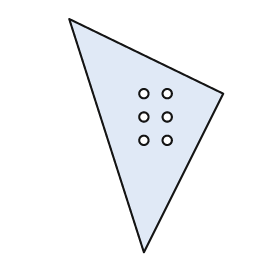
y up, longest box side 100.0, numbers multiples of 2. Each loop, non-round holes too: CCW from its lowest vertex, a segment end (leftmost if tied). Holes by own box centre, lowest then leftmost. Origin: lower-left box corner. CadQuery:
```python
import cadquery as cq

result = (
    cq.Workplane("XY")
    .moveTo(32.0, 0.0)
    .lineTo(66.0, 68.0)
    .lineTo(0.0, 100.0)
    .close()
    .moveTo(32.0, 48.0)
    .circle(2.0)
    .moveTo(42.0, 48.0)
    .circle(2.0)
    .moveTo(32.0, 58.0)
    .circle(2.0)
    .moveTo(42.0, 58.0)
    .circle(2.0)
    .moveTo(32.0, 68.0)
    .circle(2.0)
    .moveTo(42.0, 68.0)
    .circle(2.0)
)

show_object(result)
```